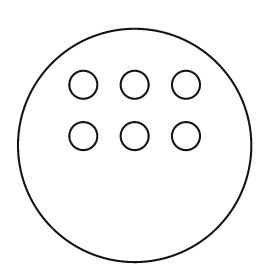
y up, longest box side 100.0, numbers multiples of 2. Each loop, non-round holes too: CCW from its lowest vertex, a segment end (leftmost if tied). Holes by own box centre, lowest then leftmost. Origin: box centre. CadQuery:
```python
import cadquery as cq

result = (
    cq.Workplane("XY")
    .moveTo(0.0, 0.0)
    .circle(50.0)
    .moveTo(-22.0, 4.0)
    .circle(6.0)
    .moveTo(0.0, 4.0)
    .circle(6.0)
    .moveTo(22.0, 4.0)
    .circle(6.0)
    .moveTo(-22.0, 26.0)
    .circle(6.0)
    .moveTo(0.0, 26.0)
    .circle(6.0)
    .moveTo(22.0, 26.0)
    .circle(6.0)
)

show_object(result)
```